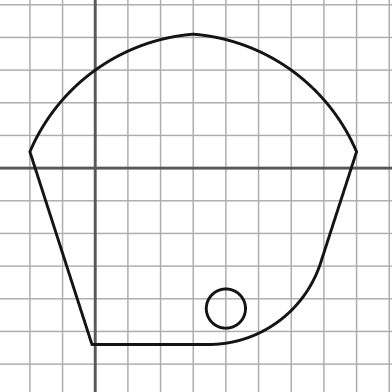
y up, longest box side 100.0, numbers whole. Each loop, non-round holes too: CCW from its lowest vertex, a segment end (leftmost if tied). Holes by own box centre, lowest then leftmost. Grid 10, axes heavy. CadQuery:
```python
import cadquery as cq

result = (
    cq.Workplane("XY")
    .moveTo(-1.0, -54.0)
    .lineTo(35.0, -54.0)
    .threePointArc((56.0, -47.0), (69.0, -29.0))
    .lineTo(80.0, 5.0)
    .threePointArc((60.0, 30.0), (30.0, 41.0))
    .threePointArc((0.0, 30.0), (-20.0, 5.0))
    .close()
    .moveTo(40.0, -43.0)
    .circle(6.0)
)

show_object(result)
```